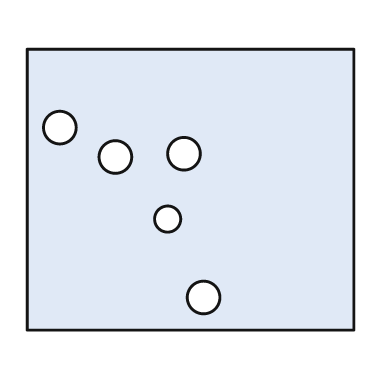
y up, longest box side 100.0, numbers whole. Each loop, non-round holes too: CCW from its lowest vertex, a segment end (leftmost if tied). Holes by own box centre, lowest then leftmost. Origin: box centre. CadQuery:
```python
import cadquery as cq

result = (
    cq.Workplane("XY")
    .moveTo(-50.0, -43.0)
    .lineTo(50.0, -43.0)
    .lineTo(50.0, 43.0)
    .lineTo(-50.0, 43.0)
    .close()
    .moveTo(4.0, -33.0)
    .circle(5.0)
    .moveTo(-7.0, -9.0)
    .circle(4.0)
    .moveTo(-23.0, 10.0)
    .circle(5.0)
    .moveTo(-2.0, 11.0)
    .circle(5.0)
    .moveTo(-40.0, 19.0)
    .circle(5.0)
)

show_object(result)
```